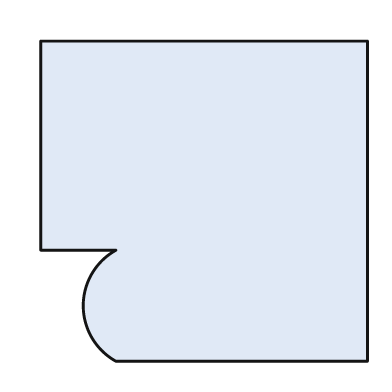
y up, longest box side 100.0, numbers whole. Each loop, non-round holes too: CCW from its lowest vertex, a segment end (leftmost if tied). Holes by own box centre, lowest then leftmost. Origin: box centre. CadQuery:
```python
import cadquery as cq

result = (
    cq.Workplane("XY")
    .moveTo(-27.0, -49.0)
    .lineTo(50.0, -49.0)
    .lineTo(50.0, 49.0)
    .lineTo(-50.0, 49.0)
    .lineTo(-50.0, -15.0)
    .lineTo(-27.0, -15.0)
    .threePointArc((-37.0, -32.0), (-27.0, -49.0))
    .close()
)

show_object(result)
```